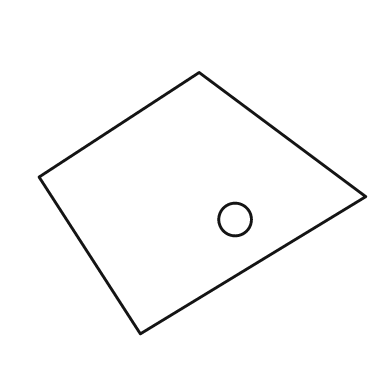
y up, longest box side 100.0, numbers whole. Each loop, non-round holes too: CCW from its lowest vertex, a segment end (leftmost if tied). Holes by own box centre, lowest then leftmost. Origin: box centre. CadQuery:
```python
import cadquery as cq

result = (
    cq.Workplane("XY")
    .moveTo(-19.0, -40.0)
    .lineTo(50.0, 2.0)
    .lineTo(-1.0, 40.0)
    .lineTo(-50.0, 8.0)
    .close()
    .moveTo(10.0, -5.0)
    .circle(5.0)
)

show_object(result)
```